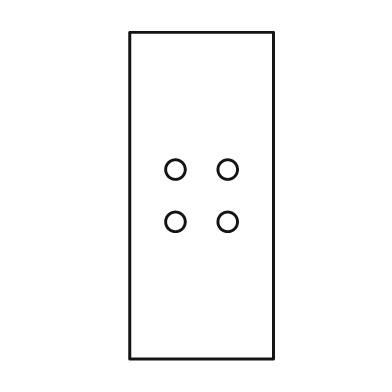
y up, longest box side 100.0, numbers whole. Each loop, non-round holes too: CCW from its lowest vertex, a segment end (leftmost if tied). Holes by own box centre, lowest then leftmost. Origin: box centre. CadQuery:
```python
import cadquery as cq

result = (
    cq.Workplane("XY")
    .moveTo(-22.0, -50.0)
    .lineTo(22.0, -50.0)
    .lineTo(22.0, 50.0)
    .lineTo(-22.0, 50.0)
    .close()
    .moveTo(-8.0, -8.0)
    .circle(3.0)
    .moveTo(8.0, -8.0)
    .circle(3.0)
    .moveTo(-8.0, 8.0)
    .circle(3.0)
    .moveTo(8.0, 8.0)
    .circle(3.0)
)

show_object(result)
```